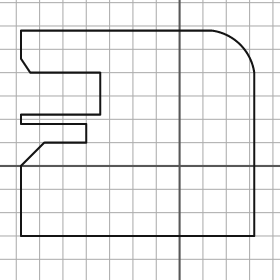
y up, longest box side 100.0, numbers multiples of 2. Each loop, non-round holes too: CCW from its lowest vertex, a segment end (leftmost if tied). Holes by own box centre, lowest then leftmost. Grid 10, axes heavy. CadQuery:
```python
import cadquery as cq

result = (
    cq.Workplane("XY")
    .moveTo(-68.0, -30.0)
    .lineTo(32.0, -30.0)
    .lineTo(32.0, 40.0)
    .threePointArc((26.0, 52.0), (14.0, 58.0))
    .lineTo(-68.0, 58.0)
    .lineTo(-68.0, 46.0)
    .lineTo(-64.0, 40.0)
    .lineTo(-34.0, 40.0)
    .lineTo(-34.0, 22.0)
    .lineTo(-68.0, 22.0)
    .lineTo(-68.0, 18.0)
    .lineTo(-40.0, 18.0)
    .lineTo(-40.0, 10.0)
    .lineTo(-58.0, 10.0)
    .lineTo(-68.0, 0.0)
    .close()
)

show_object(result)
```